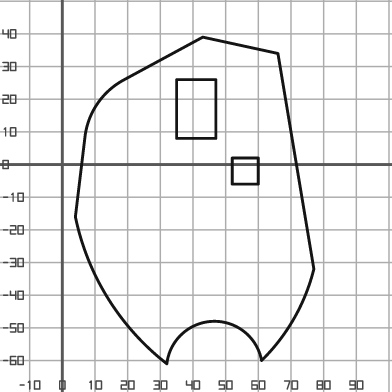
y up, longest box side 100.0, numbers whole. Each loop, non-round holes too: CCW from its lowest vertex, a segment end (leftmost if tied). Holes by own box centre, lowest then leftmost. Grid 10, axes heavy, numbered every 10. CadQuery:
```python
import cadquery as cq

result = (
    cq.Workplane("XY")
    .moveTo(32.0, -61.0)
    .threePointArc((46.0, -48.0), (61.0, -60.0))
    .threePointArc((71.0, -47.0), (77.0, -32.0))
    .lineTo(66.0, 34.0)
    .lineTo(43.0, 39.0)
    .lineTo(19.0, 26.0)
    .threePointArc((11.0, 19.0), (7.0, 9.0))
    .lineTo(4.0, -16.0)
    .threePointArc((14.0, -41.0), (32.0, -61.0))
    .close()
    .moveTo(52.0, -6.0)
    .lineTo(60.0, -6.0)
    .lineTo(60.0, 2.0)
    .lineTo(52.0, 2.0)
    .close()
    .moveTo(35.0, 8.0)
    .lineTo(47.0, 8.0)
    .lineTo(47.0, 26.0)
    .lineTo(35.0, 26.0)
    .close()
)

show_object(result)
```